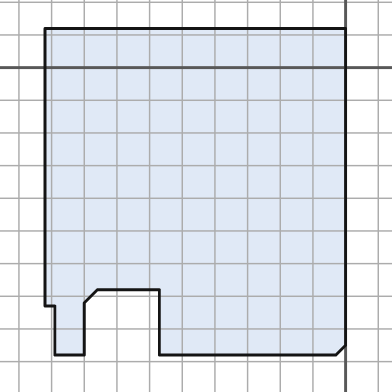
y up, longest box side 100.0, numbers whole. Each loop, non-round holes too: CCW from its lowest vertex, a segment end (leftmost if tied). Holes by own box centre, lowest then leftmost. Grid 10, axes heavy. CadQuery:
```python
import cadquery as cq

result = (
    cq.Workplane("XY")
    .moveTo(-89.0, -88.0)
    .lineTo(-80.0, -88.0)
    .lineTo(-80.0, -72.0)
    .lineTo(-76.0, -68.0)
    .lineTo(-57.0, -68.0)
    .lineTo(-57.0, -88.0)
    .lineTo(-3.0, -88.0)
    .lineTo(0.0, -85.0)
    .lineTo(0.0, 12.0)
    .lineTo(-92.0, 12.0)
    .lineTo(-92.0, -73.0)
    .lineTo(-89.0, -73.0)
    .close()
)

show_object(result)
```